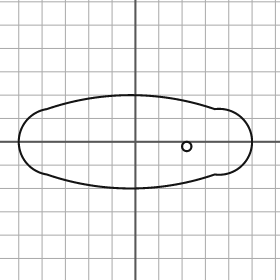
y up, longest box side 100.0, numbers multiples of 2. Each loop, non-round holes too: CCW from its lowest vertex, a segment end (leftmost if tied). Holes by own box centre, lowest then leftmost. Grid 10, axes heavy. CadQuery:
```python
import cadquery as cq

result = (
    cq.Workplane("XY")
    .moveTo(-38.0, -14.0)
    .threePointArc((-2.0, -20.0), (34.0, -14.0))
    .threePointArc((50.0, 0.0), (34.0, 14.0))
    .threePointArc((-2.0, 20.0), (-38.0, 14.0))
    .threePointArc((-50.0, 0.0), (-38.0, -14.0))
    .close()
    .moveTo(22.0, -2.0)
    .circle(2.0)
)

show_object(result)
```